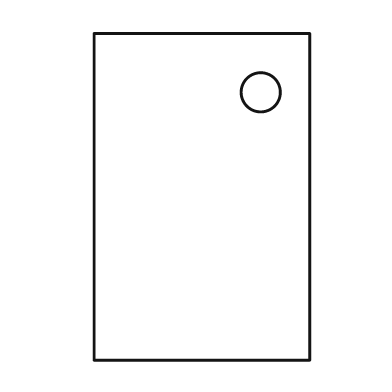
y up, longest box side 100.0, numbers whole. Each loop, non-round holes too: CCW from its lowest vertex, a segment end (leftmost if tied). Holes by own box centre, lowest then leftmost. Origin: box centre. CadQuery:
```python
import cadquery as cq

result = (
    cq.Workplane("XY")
    .moveTo(-33.0, -50.0)
    .lineTo(33.0, -50.0)
    .lineTo(33.0, 50.0)
    .lineTo(-33.0, 50.0)
    .close()
    .moveTo(18.0, 32.0)
    .circle(6.0)
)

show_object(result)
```